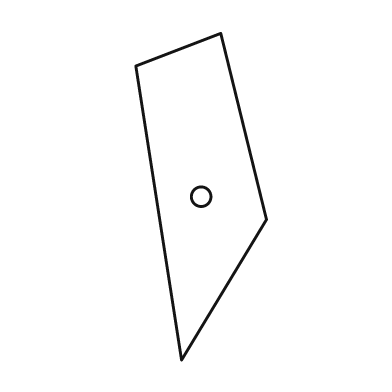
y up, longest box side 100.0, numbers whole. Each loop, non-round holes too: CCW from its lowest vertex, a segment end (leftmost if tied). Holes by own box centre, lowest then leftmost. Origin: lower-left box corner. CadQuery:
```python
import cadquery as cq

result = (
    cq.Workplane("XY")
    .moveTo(14.0, 0.0)
    .lineTo(40.0, 43.0)
    .lineTo(26.0, 100.0)
    .lineTo(0.0, 90.0)
    .close()
    .moveTo(20.0, 50.0)
    .circle(3.0)
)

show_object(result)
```